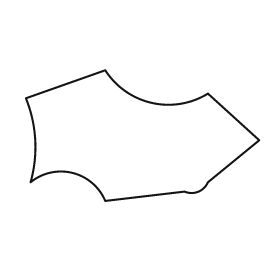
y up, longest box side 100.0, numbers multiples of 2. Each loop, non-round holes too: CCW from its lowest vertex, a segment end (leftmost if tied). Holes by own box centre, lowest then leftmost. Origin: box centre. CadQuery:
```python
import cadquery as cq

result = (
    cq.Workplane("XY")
    .moveTo(-16.0, -28.0)
    .lineTo(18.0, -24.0)
    .threePointArc((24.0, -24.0), (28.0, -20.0))
    .lineTo(50.0, -2.0)
    .lineTo(28.0, 18.0)
    .threePointArc((4.0, 14.0), (-16.0, 28.0))
    .lineTo(-50.0, 16.0)
    .threePointArc((-46.0, -2.0), (-48.0, -20.0))
    .threePointArc((-30.0, -16.0), (-16.0, -28.0))
    .close()
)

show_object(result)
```